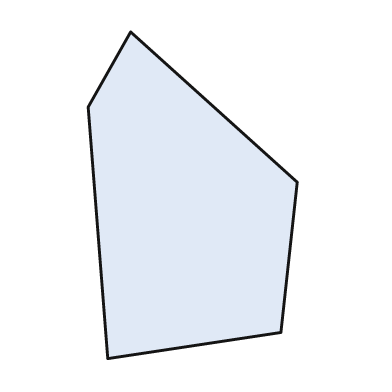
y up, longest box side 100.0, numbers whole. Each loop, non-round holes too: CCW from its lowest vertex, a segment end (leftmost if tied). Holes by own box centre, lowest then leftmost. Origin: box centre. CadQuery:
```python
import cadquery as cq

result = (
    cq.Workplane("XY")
    .moveTo(-26.0, -50.0)
    .lineTo(27.0, -42.0)
    .lineTo(32.0, 4.0)
    .lineTo(-19.0, 50.0)
    .lineTo(-32.0, 27.0)
    .close()
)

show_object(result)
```